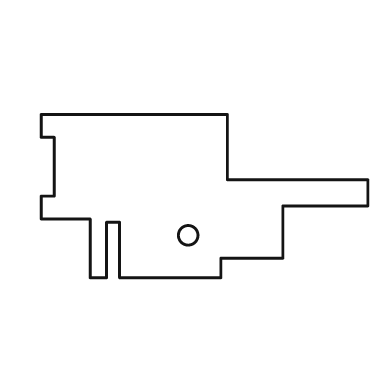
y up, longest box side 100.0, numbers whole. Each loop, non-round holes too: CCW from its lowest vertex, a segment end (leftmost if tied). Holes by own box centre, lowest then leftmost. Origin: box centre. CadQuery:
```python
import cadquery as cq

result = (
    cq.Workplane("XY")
    .moveTo(-35.0, -25.0)
    .lineTo(-30.0, -25.0)
    .lineTo(-30.0, -8.0)
    .lineTo(-26.0, -8.0)
    .lineTo(-26.0, -25.0)
    .lineTo(5.0, -25.0)
    .lineTo(5.0, -19.0)
    .lineTo(24.0, -19.0)
    .lineTo(24.0, -3.0)
    .lineTo(50.0, -3.0)
    .lineTo(50.0, 5.0)
    .lineTo(7.0, 5.0)
    .lineTo(7.0, 25.0)
    .lineTo(-50.0, 25.0)
    .lineTo(-50.0, 18.0)
    .lineTo(-46.0, 18.0)
    .lineTo(-46.0, 0.0)
    .lineTo(-50.0, 0.0)
    .lineTo(-50.0, -7.0)
    .lineTo(-35.0, -7.0)
    .close()
    .moveTo(-5.0, -12.0)
    .circle(3.0)
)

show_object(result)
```